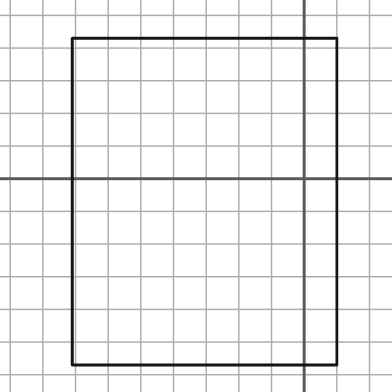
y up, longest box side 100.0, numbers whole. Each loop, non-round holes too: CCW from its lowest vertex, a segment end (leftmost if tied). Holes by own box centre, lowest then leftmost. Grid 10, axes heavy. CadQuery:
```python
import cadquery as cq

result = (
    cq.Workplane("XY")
    .moveTo(-71.0, -57.0)
    .lineTo(10.0, -57.0)
    .lineTo(10.0, 43.0)
    .lineTo(-71.0, 43.0)
    .close()
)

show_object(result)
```